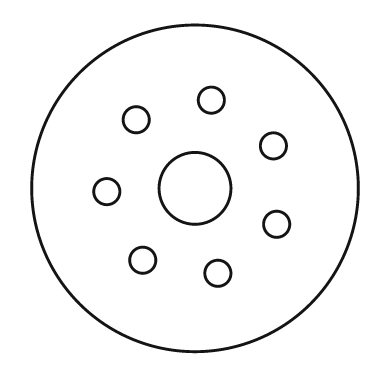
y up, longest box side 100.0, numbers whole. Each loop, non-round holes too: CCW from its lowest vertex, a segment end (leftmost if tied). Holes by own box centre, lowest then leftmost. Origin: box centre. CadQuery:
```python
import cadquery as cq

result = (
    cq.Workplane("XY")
    .moveTo(0.0, 0.0)
    .circle(50.0)
    .moveTo(7.0, -26.0)
    .circle(4.0)
    .moveTo(-16.0, -22.0)
    .circle(4.0)
    .moveTo(25.0, -11.0)
    .circle(4.0)
    .moveTo(-27.0, -1.0)
    .circle(4.0)
    .moveTo(0.0, 0.0)
    .circle(11.0)
    .moveTo(24.0, 13.0)
    .circle(4.0)
    .moveTo(-18.0, 21.0)
    .circle(4.0)
    .moveTo(5.0, 27.0)
    .circle(4.0)
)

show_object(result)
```